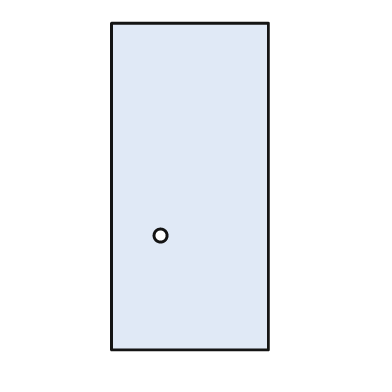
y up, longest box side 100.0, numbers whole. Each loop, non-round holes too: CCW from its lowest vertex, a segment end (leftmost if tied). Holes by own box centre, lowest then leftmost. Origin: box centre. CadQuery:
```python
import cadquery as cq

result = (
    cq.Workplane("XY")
    .moveTo(-24.0, -50.0)
    .lineTo(24.0, -50.0)
    .lineTo(24.0, 50.0)
    .lineTo(-24.0, 50.0)
    .close()
    .moveTo(-9.0, -15.0)
    .circle(2.0)
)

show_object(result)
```